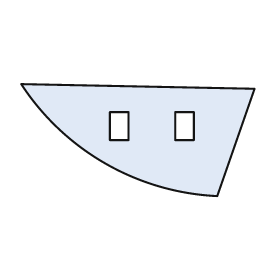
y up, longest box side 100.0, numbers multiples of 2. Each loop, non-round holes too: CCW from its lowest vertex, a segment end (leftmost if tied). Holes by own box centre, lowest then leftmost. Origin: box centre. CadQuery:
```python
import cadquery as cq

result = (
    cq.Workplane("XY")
    .moveTo(34.0, -24.0)
    .lineTo(50.0, 22.0)
    .lineTo(-50.0, 24.0)
    .threePointArc((-14.0, -10.0), (34.0, -24.0))
    .close()
    .moveTo(-12.0, 0.0)
    .lineTo(-4.0, 0.0)
    .lineTo(-4.0, 12.0)
    .lineTo(-12.0, 12.0)
    .close()
    .moveTo(16.0, 0.0)
    .lineTo(24.0, 0.0)
    .lineTo(24.0, 12.0)
    .lineTo(16.0, 12.0)
    .close()
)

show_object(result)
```